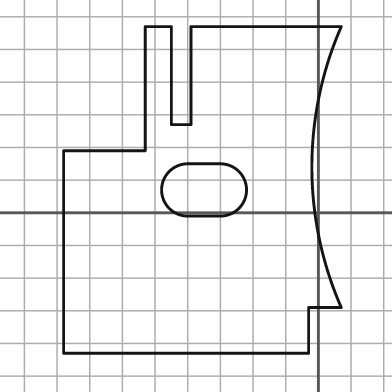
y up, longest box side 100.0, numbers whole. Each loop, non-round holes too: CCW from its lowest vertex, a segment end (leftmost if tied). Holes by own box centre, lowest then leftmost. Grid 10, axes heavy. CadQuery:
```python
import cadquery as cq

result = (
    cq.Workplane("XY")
    .moveTo(-78.0, -43.0)
    .lineTo(-3.0, -43.0)
    .lineTo(-3.0, -29.0)
    .lineTo(7.0, -29.0)
    .threePointArc((-2.0, 14.0), (7.0, 57.0))
    .lineTo(-39.0, 57.0)
    .lineTo(-39.0, 27.0)
    .lineTo(-45.0, 27.0)
    .lineTo(-45.0, 57.0)
    .lineTo(-53.0, 57.0)
    .lineTo(-53.0, 19.0)
    .lineTo(-78.0, 19.0)
    .close()
    .moveTo(-40.0, -1.0)
    .lineTo(-30.0, -1.0)
    .threePointArc((-22.0, 7.0), (-30.0, 15.0))
    .lineTo(-40.0, 15.0)
    .threePointArc((-48.0, 7.0), (-40.0, -1.0))
    .close()
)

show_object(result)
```